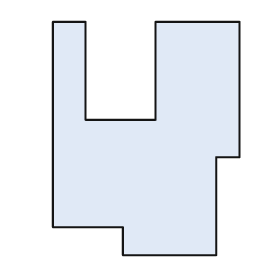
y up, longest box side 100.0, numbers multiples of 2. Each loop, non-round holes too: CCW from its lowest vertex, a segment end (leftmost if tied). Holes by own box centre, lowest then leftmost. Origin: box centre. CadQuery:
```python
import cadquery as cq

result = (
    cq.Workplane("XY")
    .moveTo(-10.0, -50.0)
    .lineTo(30.0, -50.0)
    .lineTo(30.0, -8.0)
    .lineTo(40.0, -8.0)
    .lineTo(40.0, 50.0)
    .lineTo(4.0, 50.0)
    .lineTo(4.0, 8.0)
    .lineTo(-26.0, 8.0)
    .lineTo(-26.0, 50.0)
    .lineTo(-40.0, 50.0)
    .lineTo(-40.0, -38.0)
    .lineTo(-10.0, -38.0)
    .close()
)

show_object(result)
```